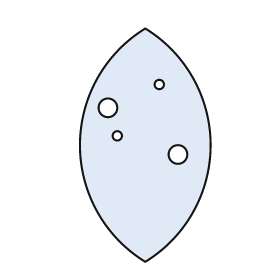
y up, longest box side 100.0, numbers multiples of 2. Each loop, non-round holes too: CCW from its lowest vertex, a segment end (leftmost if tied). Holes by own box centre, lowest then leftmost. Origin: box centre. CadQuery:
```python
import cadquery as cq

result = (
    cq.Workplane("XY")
    .moveTo(0.0, -50.0)
    .threePointArc((28.0, 0.0), (0.0, 50.0))
    .threePointArc((-28.0, 0.0), (0.0, -50.0))
    .close()
    .moveTo(14.0, -4.0)
    .circle(4.0)
    .moveTo(-12.0, 4.0)
    .circle(2.0)
    .moveTo(-16.0, 16.0)
    .circle(4.0)
    .moveTo(6.0, 26.0)
    .circle(2.0)
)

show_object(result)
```